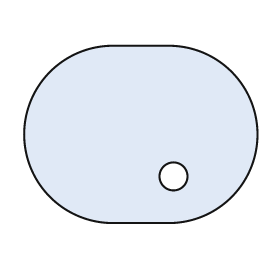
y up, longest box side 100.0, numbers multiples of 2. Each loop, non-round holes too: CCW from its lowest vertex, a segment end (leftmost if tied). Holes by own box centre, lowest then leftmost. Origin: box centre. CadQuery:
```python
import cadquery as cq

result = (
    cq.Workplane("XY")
    .moveTo(-12.0, -38.0)
    .lineTo(12.0, -38.0)
    .threePointArc((50.0, 0.0), (12.0, 38.0))
    .lineTo(-12.0, 38.0)
    .threePointArc((-50.0, 0.0), (-12.0, -38.0))
    .close()
    .moveTo(14.0, -18.0)
    .circle(6.0)
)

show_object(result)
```